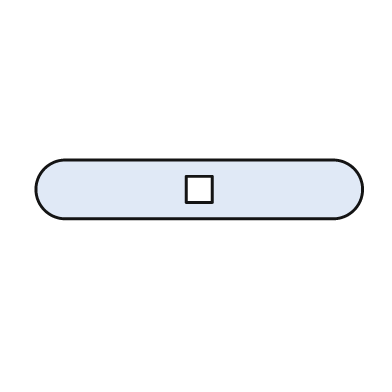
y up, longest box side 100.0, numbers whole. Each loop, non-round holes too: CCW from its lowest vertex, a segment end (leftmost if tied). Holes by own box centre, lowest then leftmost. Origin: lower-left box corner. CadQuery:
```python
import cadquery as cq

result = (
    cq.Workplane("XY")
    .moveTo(9.0, 0.0)
    .lineTo(91.0, 0.0)
    .threePointArc((100.0, 9.0), (91.0, 18.0))
    .lineTo(9.0, 18.0)
    .threePointArc((0.0, 9.0), (9.0, 0.0))
    .close()
    .moveTo(46.0, 5.0)
    .lineTo(54.0, 5.0)
    .lineTo(54.0, 13.0)
    .lineTo(46.0, 13.0)
    .close()
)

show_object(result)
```